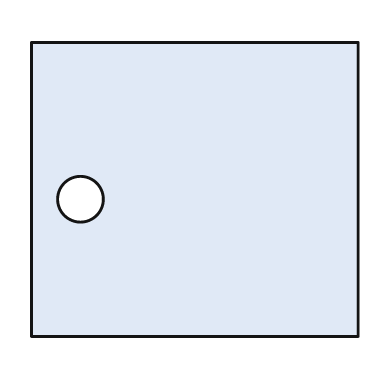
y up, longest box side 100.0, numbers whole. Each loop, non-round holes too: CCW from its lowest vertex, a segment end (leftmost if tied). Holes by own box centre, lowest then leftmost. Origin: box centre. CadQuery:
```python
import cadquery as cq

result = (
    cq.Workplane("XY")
    .moveTo(-50.0, -45.0)
    .lineTo(50.0, -45.0)
    .lineTo(50.0, 45.0)
    .lineTo(-50.0, 45.0)
    .close()
    .moveTo(-35.0, -3.0)
    .circle(7.0)
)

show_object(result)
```